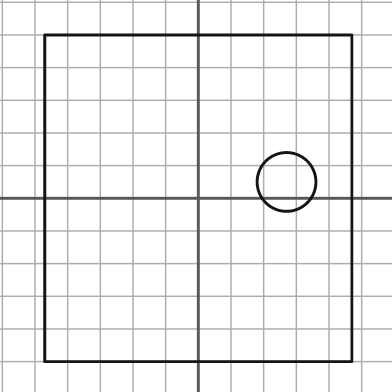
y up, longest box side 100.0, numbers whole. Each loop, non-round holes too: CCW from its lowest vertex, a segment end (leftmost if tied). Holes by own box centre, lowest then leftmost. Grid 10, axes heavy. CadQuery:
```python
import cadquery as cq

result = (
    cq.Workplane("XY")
    .moveTo(-47.0, -50.0)
    .lineTo(47.0, -50.0)
    .lineTo(47.0, 50.0)
    .lineTo(-47.0, 50.0)
    .close()
    .moveTo(27.0, 5.0)
    .circle(9.0)
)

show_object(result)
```